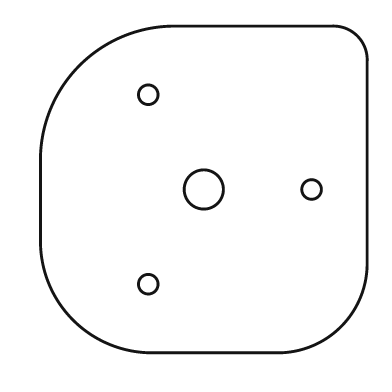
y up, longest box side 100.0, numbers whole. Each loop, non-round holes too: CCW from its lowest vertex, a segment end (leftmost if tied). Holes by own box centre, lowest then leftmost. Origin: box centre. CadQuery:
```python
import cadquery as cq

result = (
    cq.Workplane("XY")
    .moveTo(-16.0, -50.0)
    .lineTo(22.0, -50.0)
    .threePointArc((42.0, -42.0), (50.0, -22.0))
    .lineTo(50.0, 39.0)
    .threePointArc((47.0, 47.0), (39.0, 50.0))
    .lineTo(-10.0, 50.0)
    .threePointArc((-38.0, 38.0), (-50.0, 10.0))
    .lineTo(-50.0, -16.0)
    .threePointArc((-40.0, -40.0), (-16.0, -50.0))
    .close()
    .moveTo(-17.0, -29.0)
    .circle(3.0)
    .moveTo(0.0, 0.0)
    .circle(6.0)
    .moveTo(33.0, 0.0)
    .circle(3.0)
    .moveTo(-17.0, 29.0)
    .circle(3.0)
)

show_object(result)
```